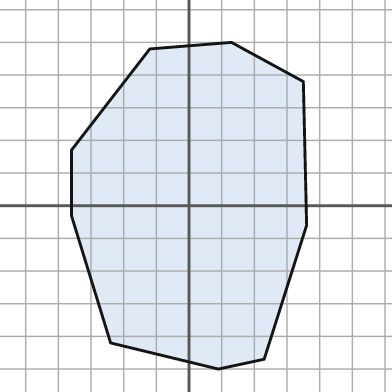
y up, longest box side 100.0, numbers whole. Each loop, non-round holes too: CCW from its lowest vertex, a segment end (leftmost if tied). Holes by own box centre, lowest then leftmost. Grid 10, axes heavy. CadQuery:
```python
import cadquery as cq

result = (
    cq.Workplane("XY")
    .moveTo(9.0, -50.0)
    .lineTo(23.0, -47.0)
    .lineTo(36.0, -6.0)
    .lineTo(35.0, 38.0)
    .lineTo(13.0, 50.0)
    .lineTo(-12.0, 48.0)
    .lineTo(-36.0, 17.0)
    .lineTo(-36.0, -3.0)
    .lineTo(-24.0, -42.0)
    .close()
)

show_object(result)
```